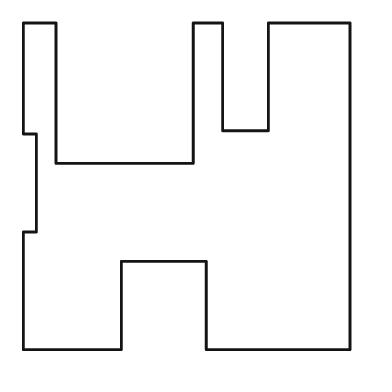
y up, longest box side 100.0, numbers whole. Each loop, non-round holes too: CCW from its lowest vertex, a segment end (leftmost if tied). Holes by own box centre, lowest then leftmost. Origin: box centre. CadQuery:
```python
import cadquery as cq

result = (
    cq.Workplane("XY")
    .moveTo(-50.0, -50.0)
    .lineTo(-20.0, -50.0)
    .lineTo(-20.0, -23.0)
    .lineTo(6.0, -23.0)
    .lineTo(6.0, -50.0)
    .lineTo(50.0, -50.0)
    .lineTo(50.0, 50.0)
    .lineTo(25.0, 50.0)
    .lineTo(25.0, 17.0)
    .lineTo(11.0, 17.0)
    .lineTo(11.0, 50.0)
    .lineTo(2.0, 50.0)
    .lineTo(2.0, 7.0)
    .lineTo(-40.0, 7.0)
    .lineTo(-40.0, 50.0)
    .lineTo(-50.0, 50.0)
    .lineTo(-50.0, 16.0)
    .lineTo(-46.0, 16.0)
    .lineTo(-46.0, -14.0)
    .lineTo(-50.0, -14.0)
    .close()
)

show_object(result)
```